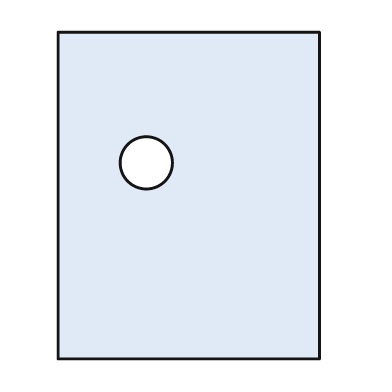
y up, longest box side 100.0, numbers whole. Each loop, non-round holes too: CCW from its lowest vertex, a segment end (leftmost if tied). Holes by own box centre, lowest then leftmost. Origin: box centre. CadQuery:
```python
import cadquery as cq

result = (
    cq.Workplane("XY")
    .moveTo(-40.0, -50.0)
    .lineTo(40.0, -50.0)
    .lineTo(40.0, 50.0)
    .lineTo(-40.0, 50.0)
    .close()
    .moveTo(-13.0, 10.0)
    .circle(8.0)
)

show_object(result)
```